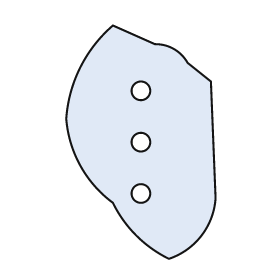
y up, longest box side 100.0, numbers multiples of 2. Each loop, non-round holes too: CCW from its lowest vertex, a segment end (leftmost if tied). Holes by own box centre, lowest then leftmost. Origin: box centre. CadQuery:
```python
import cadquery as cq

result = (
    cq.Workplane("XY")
    .moveTo(12.0, -50.0)
    .threePointArc((26.0, -40.0), (32.0, -24.0))
    .lineTo(30.0, 26.0)
    .lineTo(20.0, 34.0)
    .threePointArc((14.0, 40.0), (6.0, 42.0))
    .lineTo(-12.0, 50.0)
    .threePointArc((-26.0, 32.0), (-32.0, 10.0))
    .threePointArc((-26.0, -10.0), (-12.0, -26.0))
    .threePointArc((-2.0, -40.0), (12.0, -50.0))
    .close()
    .moveTo(0.0, -22.0)
    .circle(4.0)
    .moveTo(0.0, 0.0)
    .circle(4.0)
    .moveTo(0.0, 22.0)
    .circle(4.0)
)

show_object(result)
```